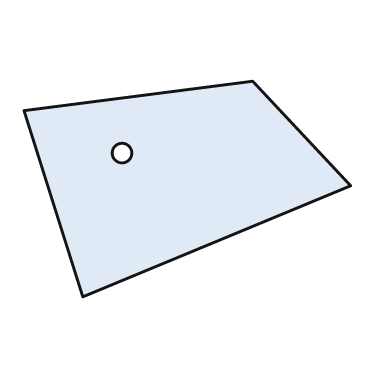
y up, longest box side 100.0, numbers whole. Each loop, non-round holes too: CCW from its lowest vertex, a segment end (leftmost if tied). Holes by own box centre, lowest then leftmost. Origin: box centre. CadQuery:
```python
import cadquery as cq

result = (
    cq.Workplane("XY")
    .moveTo(-32.0, -33.0)
    .lineTo(50.0, 1.0)
    .lineTo(20.0, 33.0)
    .lineTo(-50.0, 24.0)
    .close()
    .moveTo(-20.0, 11.0)
    .circle(3.0)
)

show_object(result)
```